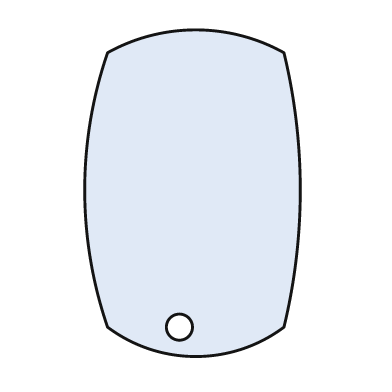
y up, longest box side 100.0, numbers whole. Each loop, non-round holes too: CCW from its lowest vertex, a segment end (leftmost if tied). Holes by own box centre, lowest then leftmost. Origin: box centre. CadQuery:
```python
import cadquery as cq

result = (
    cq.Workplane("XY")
    .moveTo(-26.0, -41.0)
    .threePointArc((1.0, -50.0), (28.0, -41.0))
    .threePointArc((33.0, 1.0), (28.0, 43.0))
    .threePointArc((1.0, 50.0), (-26.0, 43.0))
    .threePointArc((-33.0, 1.0), (-26.0, -41.0))
    .close()
    .moveTo(-4.0, -41.0)
    .circle(4.0)
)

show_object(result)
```